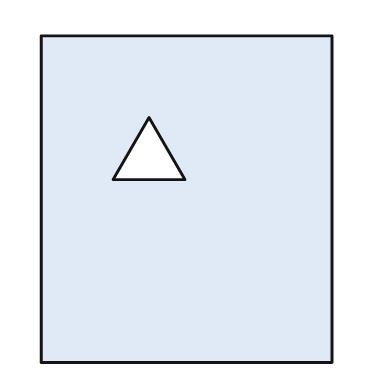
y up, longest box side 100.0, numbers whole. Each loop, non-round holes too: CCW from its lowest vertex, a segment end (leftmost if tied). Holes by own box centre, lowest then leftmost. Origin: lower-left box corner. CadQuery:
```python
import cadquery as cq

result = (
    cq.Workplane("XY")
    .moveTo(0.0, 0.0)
    .lineTo(89.0, 0.0)
    .lineTo(89.0, 100.0)
    .lineTo(0.0, 100.0)
    .close()
    .moveTo(22.0, 56.0)
    .lineTo(44.0, 56.0)
    .lineTo(33.0, 75.0)
    .close()
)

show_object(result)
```